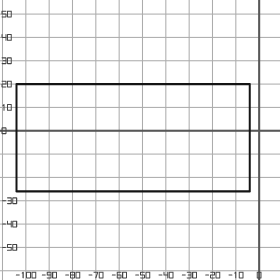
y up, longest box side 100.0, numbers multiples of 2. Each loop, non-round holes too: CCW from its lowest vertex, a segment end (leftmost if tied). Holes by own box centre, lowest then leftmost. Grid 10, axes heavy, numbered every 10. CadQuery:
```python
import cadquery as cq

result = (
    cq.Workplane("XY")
    .moveTo(-104.0, -26.0)
    .lineTo(-4.0, -26.0)
    .lineTo(-4.0, 20.0)
    .lineTo(-104.0, 20.0)
    .close()
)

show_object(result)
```